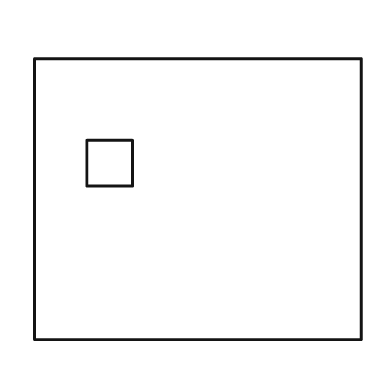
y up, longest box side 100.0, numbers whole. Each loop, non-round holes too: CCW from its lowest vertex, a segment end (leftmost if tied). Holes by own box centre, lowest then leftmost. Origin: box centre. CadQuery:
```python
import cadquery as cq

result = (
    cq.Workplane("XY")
    .moveTo(-50.0, -43.0)
    .lineTo(50.0, -43.0)
    .lineTo(50.0, 43.0)
    .lineTo(-50.0, 43.0)
    .close()
    .moveTo(-34.0, 4.0)
    .lineTo(-20.0, 4.0)
    .lineTo(-20.0, 18.0)
    .lineTo(-34.0, 18.0)
    .close()
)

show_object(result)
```